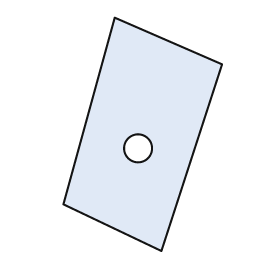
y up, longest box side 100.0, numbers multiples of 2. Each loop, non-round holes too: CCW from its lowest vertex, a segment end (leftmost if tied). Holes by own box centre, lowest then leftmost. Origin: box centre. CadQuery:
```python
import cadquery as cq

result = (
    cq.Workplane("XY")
    .moveTo(8.0, -50.0)
    .lineTo(34.0, 30.0)
    .lineTo(-12.0, 50.0)
    .lineTo(-34.0, -30.0)
    .close()
    .moveTo(-2.0, -6.0)
    .circle(6.0)
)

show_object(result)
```